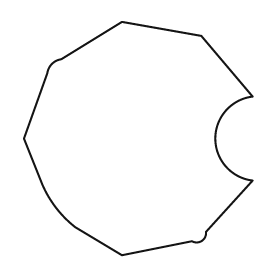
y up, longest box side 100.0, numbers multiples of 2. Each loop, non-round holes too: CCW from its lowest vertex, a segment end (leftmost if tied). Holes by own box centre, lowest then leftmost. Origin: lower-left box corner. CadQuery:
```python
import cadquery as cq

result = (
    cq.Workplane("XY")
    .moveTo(42.0, 0.0)
    .lineTo(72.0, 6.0)
    .threePointArc((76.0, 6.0), (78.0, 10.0))
    .lineTo(98.0, 32.0)
    .threePointArc((82.0, 50.0), (98.0, 68.0))
    .lineTo(76.0, 94.0)
    .lineTo(42.0, 100.0)
    .lineTo(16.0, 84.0)
    .threePointArc((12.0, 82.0), (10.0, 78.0))
    .lineTo(0.0, 50.0)
    .lineTo(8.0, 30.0)
    .threePointArc((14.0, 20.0), (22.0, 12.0))
    .close()
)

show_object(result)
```